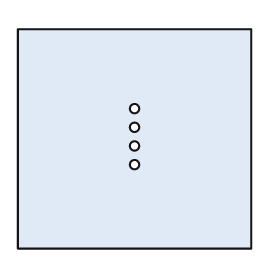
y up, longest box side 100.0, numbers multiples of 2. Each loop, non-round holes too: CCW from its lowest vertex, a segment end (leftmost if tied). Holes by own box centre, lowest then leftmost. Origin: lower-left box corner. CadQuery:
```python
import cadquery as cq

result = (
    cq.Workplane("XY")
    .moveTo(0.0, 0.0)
    .lineTo(100.0, 0.0)
    .lineTo(100.0, 94.0)
    .lineTo(0.0, 94.0)
    .close()
    .moveTo(50.0, 36.0)
    .circle(2.0)
    .moveTo(50.0, 44.0)
    .circle(2.0)
    .moveTo(50.0, 52.0)
    .circle(2.0)
    .moveTo(50.0, 60.0)
    .circle(2.0)
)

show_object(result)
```